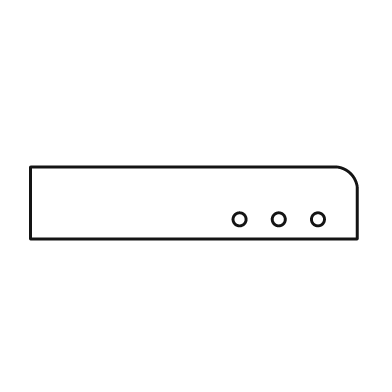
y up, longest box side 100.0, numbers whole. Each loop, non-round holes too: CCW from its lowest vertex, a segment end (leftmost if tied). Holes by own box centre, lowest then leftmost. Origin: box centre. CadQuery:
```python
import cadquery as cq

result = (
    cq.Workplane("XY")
    .moveTo(-50.0, -11.0)
    .lineTo(50.0, -11.0)
    .lineTo(50.0, 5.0)
    .threePointArc((48.0, 9.0), (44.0, 11.0))
    .lineTo(-50.0, 11.0)
    .close()
    .moveTo(14.0, -5.0)
    .circle(2.0)
    .moveTo(26.0, -5.0)
    .circle(2.0)
    .moveTo(38.0, -5.0)
    .circle(2.0)
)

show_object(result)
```